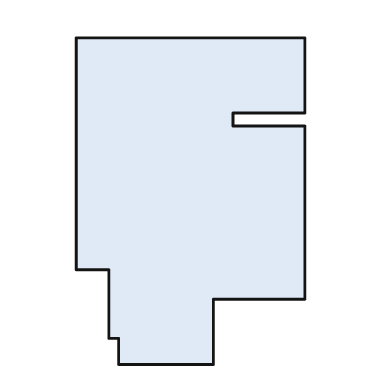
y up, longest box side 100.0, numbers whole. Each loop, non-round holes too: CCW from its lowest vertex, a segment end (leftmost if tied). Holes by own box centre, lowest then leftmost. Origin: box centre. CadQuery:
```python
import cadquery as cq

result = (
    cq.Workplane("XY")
    .moveTo(-22.0, -50.0)
    .lineTo(7.0, -50.0)
    .lineTo(7.0, -30.0)
    .lineTo(35.0, -30.0)
    .lineTo(35.0, 23.0)
    .lineTo(13.0, 23.0)
    .lineTo(13.0, 27.0)
    .lineTo(35.0, 27.0)
    .lineTo(35.0, 50.0)
    .lineTo(-35.0, 50.0)
    .lineTo(-35.0, -21.0)
    .lineTo(-25.0, -21.0)
    .lineTo(-25.0, -42.0)
    .lineTo(-22.0, -42.0)
    .close()
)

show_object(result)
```